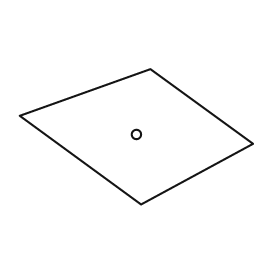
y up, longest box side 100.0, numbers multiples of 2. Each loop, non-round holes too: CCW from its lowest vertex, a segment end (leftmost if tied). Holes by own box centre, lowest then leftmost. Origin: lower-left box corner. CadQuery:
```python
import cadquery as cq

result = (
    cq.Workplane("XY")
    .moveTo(52.0, 0.0)
    .lineTo(100.0, 26.0)
    .lineTo(56.0, 58.0)
    .lineTo(0.0, 38.0)
    .close()
    .moveTo(50.0, 30.0)
    .circle(2.0)
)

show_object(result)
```